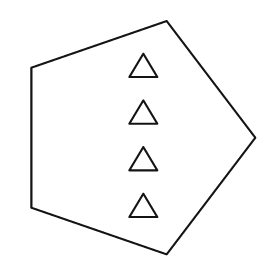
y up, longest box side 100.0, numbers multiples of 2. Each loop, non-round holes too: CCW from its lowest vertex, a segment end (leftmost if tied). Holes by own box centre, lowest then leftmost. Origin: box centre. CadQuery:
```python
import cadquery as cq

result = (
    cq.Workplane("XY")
    .moveTo(10.0, -50.0)
    .lineTo(48.0, 0.0)
    .lineTo(10.0, 50.0)
    .lineTo(-48.0, 30.0)
    .lineTo(-48.0, -30.0)
    .close()
    .moveTo(-6.0, -34.0)
    .lineTo(6.0, -34.0)
    .lineTo(0.0, -24.0)
    .close()
    .moveTo(-6.0, -14.0)
    .lineTo(6.0, -14.0)
    .lineTo(0.0, -4.0)
    .close()
    .moveTo(-6.0, 6.0)
    .lineTo(6.0, 6.0)
    .lineTo(0.0, 16.0)
    .close()
    .moveTo(-6.0, 26.0)
    .lineTo(6.0, 26.0)
    .lineTo(0.0, 36.0)
    .close()
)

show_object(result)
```